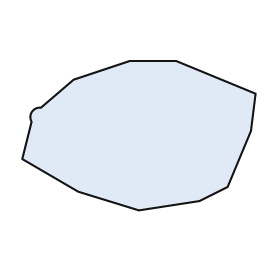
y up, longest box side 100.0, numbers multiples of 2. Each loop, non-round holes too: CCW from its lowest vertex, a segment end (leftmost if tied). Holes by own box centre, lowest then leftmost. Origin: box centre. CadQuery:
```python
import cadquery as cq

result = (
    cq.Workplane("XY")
    .moveTo(0.0, -32.0)
    .lineTo(26.0, -28.0)
    .lineTo(38.0, -22.0)
    .lineTo(48.0, 2.0)
    .lineTo(50.0, 18.0)
    .lineTo(16.0, 32.0)
    .lineTo(-4.0, 32.0)
    .lineTo(-28.0, 24.0)
    .lineTo(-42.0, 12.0)
    .threePointArc((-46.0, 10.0), (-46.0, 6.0))
    .lineTo(-50.0, -10.0)
    .lineTo(-26.0, -24.0)
    .close()
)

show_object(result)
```